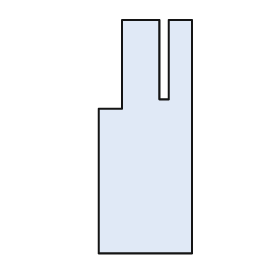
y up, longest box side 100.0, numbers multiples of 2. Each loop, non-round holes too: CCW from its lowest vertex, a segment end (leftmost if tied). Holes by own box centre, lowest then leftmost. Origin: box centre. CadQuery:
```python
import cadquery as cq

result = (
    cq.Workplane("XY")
    .moveTo(-20.0, -50.0)
    .lineTo(20.0, -50.0)
    .lineTo(20.0, 50.0)
    .lineTo(10.0, 50.0)
    .lineTo(10.0, 16.0)
    .lineTo(6.0, 16.0)
    .lineTo(6.0, 50.0)
    .lineTo(-10.0, 50.0)
    .lineTo(-10.0, 12.0)
    .lineTo(-20.0, 12.0)
    .close()
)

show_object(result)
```